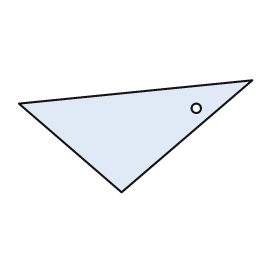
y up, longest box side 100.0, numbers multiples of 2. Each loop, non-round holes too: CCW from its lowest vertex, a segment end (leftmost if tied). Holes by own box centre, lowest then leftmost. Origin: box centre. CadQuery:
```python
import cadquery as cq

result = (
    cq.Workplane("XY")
    .moveTo(-6.0, -24.0)
    .lineTo(50.0, 24.0)
    .lineTo(-50.0, 14.0)
    .close()
    .moveTo(26.0, 12.0)
    .circle(2.0)
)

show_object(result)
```